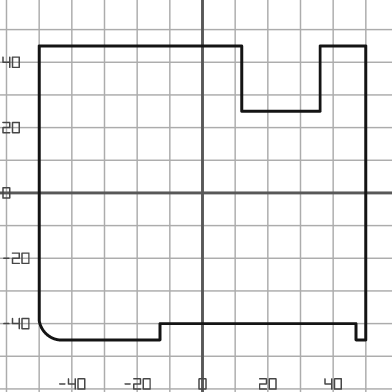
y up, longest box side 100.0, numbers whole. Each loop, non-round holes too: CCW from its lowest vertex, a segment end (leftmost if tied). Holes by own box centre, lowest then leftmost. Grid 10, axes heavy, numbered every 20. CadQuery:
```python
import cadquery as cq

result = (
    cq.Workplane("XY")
    .moveTo(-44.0, -45.0)
    .lineTo(-13.0, -45.0)
    .lineTo(-13.0, -40.0)
    .lineTo(47.0, -40.0)
    .lineTo(47.0, -45.0)
    .lineTo(50.0, -45.0)
    .lineTo(50.0, 45.0)
    .lineTo(36.0, 45.0)
    .lineTo(36.0, 25.0)
    .lineTo(12.0, 25.0)
    .lineTo(12.0, 45.0)
    .lineTo(-50.0, 45.0)
    .lineTo(-50.0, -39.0)
    .threePointArc((-48.0, -43.0), (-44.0, -45.0))
    .close()
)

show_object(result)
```